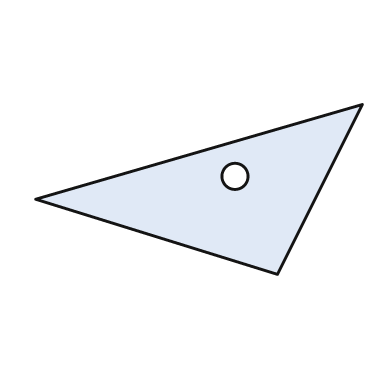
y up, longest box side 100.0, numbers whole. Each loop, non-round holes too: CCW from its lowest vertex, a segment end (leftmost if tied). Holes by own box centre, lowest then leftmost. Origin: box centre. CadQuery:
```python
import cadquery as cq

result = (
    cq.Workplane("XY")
    .moveTo(24.0, -26.0)
    .lineTo(50.0, 26.0)
    .lineTo(-50.0, -3.0)
    .close()
    .moveTo(11.0, 4.0)
    .circle(4.0)
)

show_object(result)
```